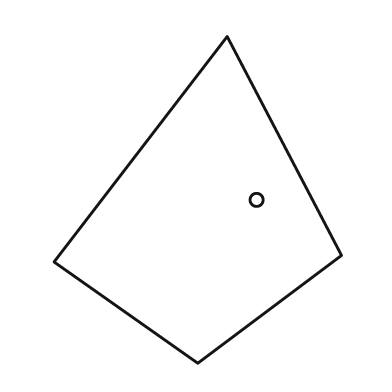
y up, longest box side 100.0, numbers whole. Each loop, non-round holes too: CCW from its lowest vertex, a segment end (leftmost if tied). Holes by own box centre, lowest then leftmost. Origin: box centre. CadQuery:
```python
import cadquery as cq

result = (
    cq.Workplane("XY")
    .moveTo(0.0, -50.0)
    .lineTo(44.0, -17.0)
    .lineTo(9.0, 50.0)
    .lineTo(-44.0, -19.0)
    .close()
    .moveTo(18.0, 0.0)
    .circle(2.0)
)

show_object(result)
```